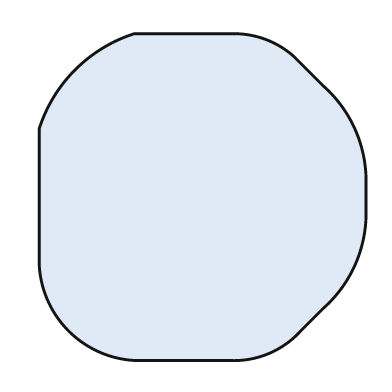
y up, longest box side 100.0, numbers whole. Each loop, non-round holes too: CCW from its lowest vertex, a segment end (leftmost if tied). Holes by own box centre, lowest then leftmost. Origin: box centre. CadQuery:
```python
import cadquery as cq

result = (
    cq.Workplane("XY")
    .moveTo(-21.0, -50.0)
    .lineTo(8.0, -50.0)
    .threePointArc((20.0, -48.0), (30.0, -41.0))
    .lineTo(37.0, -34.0)
    .threePointArc((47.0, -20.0), (50.0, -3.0))
    .lineTo(50.0, 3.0)
    .threePointArc((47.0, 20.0), (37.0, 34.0))
    .lineTo(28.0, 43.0)
    .threePointArc((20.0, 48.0), (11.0, 50.0))
    .lineTo(-21.0, 50.0)
    .threePointArc((-39.0, 39.0), (-50.0, 21.0))
    .lineTo(-50.0, -21.0)
    .threePointArc((-41.0, -41.0), (-21.0, -50.0))
    .close()
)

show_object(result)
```